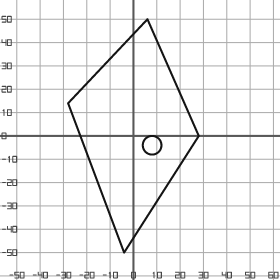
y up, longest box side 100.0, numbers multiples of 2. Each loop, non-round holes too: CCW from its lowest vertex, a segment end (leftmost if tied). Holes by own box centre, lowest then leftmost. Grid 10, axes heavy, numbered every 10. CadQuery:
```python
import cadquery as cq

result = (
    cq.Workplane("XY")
    .moveTo(-4.0, -50.0)
    .lineTo(28.0, 0.0)
    .lineTo(6.0, 50.0)
    .lineTo(-28.0, 14.0)
    .close()
    .moveTo(8.0, -4.0)
    .circle(4.0)
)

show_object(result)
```